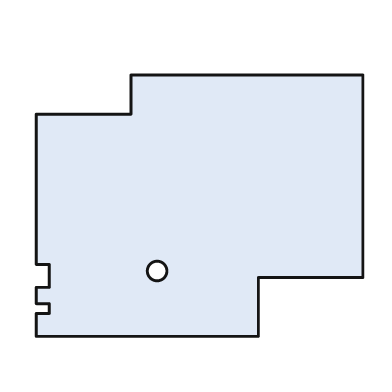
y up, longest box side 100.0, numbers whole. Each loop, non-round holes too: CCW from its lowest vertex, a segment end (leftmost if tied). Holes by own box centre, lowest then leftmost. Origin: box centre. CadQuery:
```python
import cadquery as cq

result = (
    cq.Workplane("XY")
    .moveTo(-50.0, -40.0)
    .lineTo(18.0, -40.0)
    .lineTo(18.0, -22.0)
    .lineTo(50.0, -22.0)
    .lineTo(50.0, 40.0)
    .lineTo(-21.0, 40.0)
    .lineTo(-21.0, 28.0)
    .lineTo(-50.0, 28.0)
    .lineTo(-50.0, -18.0)
    .lineTo(-46.0, -18.0)
    .lineTo(-46.0, -25.0)
    .lineTo(-50.0, -25.0)
    .lineTo(-50.0, -30.0)
    .lineTo(-46.0, -30.0)
    .lineTo(-46.0, -33.0)
    .lineTo(-50.0, -33.0)
    .close()
    .moveTo(-13.0, -20.0)
    .circle(3.0)
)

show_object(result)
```